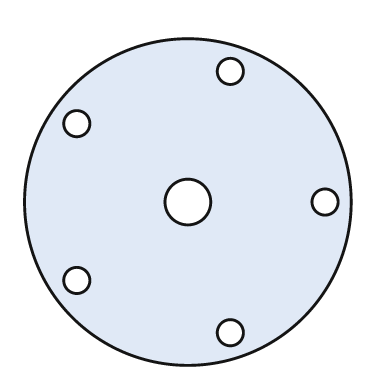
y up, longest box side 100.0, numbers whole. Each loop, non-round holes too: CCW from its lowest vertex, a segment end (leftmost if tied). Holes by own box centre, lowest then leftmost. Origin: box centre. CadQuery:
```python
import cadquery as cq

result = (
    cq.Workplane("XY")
    .moveTo(0.0, 0.0)
    .circle(50.0)
    .moveTo(13.0, -40.0)
    .circle(4.0)
    .moveTo(-34.0, -24.0)
    .circle(4.0)
    .moveTo(0.0, 0.0)
    .circle(7.0)
    .moveTo(42.0, 0.0)
    .circle(4.0)
    .moveTo(-34.0, 24.0)
    .circle(4.0)
    .moveTo(13.0, 40.0)
    .circle(4.0)
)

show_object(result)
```